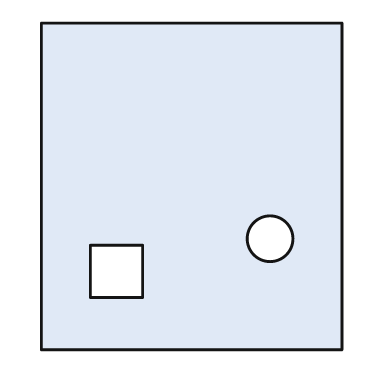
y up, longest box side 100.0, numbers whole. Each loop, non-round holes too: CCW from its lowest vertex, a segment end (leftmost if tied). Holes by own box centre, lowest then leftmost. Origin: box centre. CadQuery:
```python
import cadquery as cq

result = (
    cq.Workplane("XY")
    .moveTo(-46.0, -50.0)
    .lineTo(46.0, -50.0)
    .lineTo(46.0, 50.0)
    .lineTo(-46.0, 50.0)
    .close()
    .moveTo(-31.0, -34.0)
    .lineTo(-15.0, -34.0)
    .lineTo(-15.0, -18.0)
    .lineTo(-31.0, -18.0)
    .close()
    .moveTo(24.0, -16.0)
    .circle(7.0)
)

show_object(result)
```